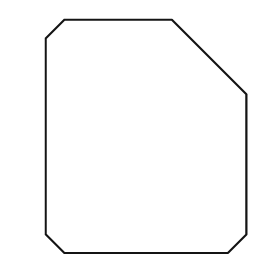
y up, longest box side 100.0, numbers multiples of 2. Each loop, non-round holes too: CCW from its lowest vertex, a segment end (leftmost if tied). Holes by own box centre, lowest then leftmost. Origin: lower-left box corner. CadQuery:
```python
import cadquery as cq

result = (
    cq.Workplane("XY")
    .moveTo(8.0, 0.0)
    .lineTo(78.0, 0.0)
    .lineTo(86.0, 8.0)
    .lineTo(86.0, 68.0)
    .lineTo(54.0, 100.0)
    .lineTo(8.0, 100.0)
    .lineTo(0.0, 92.0)
    .lineTo(0.0, 8.0)
    .close()
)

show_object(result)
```